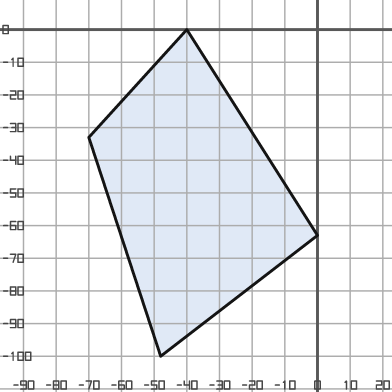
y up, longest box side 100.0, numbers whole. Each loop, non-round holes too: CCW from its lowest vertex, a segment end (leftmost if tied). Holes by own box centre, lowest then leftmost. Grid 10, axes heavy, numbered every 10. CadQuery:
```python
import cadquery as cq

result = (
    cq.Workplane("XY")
    .moveTo(-48.0, -100.0)
    .lineTo(0.0, -63.0)
    .lineTo(-40.0, 0.0)
    .lineTo(-70.0, -33.0)
    .close()
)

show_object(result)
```